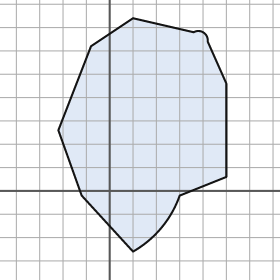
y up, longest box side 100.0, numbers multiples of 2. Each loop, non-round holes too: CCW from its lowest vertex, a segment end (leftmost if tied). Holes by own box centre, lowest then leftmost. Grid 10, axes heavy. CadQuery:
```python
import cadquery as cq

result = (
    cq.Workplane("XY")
    .moveTo(10.0, -26.0)
    .threePointArc((22.0, -16.0), (30.0, -2.0))
    .lineTo(50.0, 6.0)
    .lineTo(50.0, 46.0)
    .lineTo(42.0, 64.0)
    .threePointArc((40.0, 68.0), (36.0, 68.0))
    .lineTo(10.0, 74.0)
    .lineTo(-8.0, 62.0)
    .lineTo(-22.0, 26.0)
    .lineTo(-12.0, -2.0)
    .close()
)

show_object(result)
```